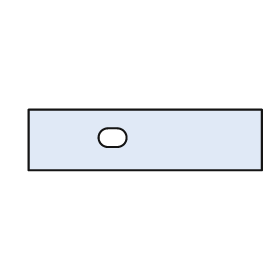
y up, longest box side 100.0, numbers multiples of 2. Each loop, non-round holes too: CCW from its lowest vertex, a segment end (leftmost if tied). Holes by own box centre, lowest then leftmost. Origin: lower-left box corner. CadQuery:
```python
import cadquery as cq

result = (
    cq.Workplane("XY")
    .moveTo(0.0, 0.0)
    .lineTo(100.0, 0.0)
    .lineTo(100.0, 26.0)
    .lineTo(0.0, 26.0)
    .close()
    .moveTo(34.0, 10.0)
    .lineTo(38.0, 10.0)
    .threePointArc((42.0, 14.0), (38.0, 18.0))
    .lineTo(34.0, 18.0)
    .threePointArc((30.0, 14.0), (34.0, 10.0))
    .close()
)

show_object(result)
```